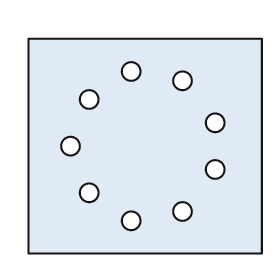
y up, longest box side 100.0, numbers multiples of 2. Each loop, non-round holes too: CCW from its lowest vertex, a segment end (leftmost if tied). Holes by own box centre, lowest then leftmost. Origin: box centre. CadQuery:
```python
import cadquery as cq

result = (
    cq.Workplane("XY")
    .moveTo(-50.0, -46.0)
    .lineTo(50.0, -46.0)
    .lineTo(50.0, 46.0)
    .lineTo(-50.0, 46.0)
    .close()
    .moveTo(-6.0, -32.0)
    .circle(4.0)
    .moveTo(16.0, -28.0)
    .circle(4.0)
    .moveTo(-24.0, -20.0)
    .circle(4.0)
    .moveTo(30.0, -10.0)
    .circle(4.0)
    .moveTo(-32.0, 0.0)
    .circle(4.0)
    .moveTo(30.0, 10.0)
    .circle(4.0)
    .moveTo(-24.0, 20.0)
    .circle(4.0)
    .moveTo(16.0, 28.0)
    .circle(4.0)
    .moveTo(-6.0, 32.0)
    .circle(4.0)
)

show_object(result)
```